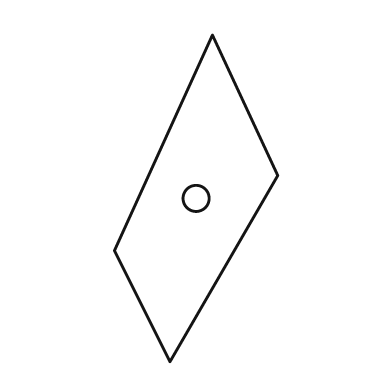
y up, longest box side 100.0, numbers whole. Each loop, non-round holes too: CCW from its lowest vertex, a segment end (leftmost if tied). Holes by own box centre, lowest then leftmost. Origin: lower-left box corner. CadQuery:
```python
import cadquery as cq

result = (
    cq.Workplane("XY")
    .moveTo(17.0, 0.0)
    .lineTo(50.0, 57.0)
    .lineTo(30.0, 100.0)
    .lineTo(0.0, 34.0)
    .close()
    .moveTo(25.0, 50.0)
    .circle(4.0)
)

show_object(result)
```